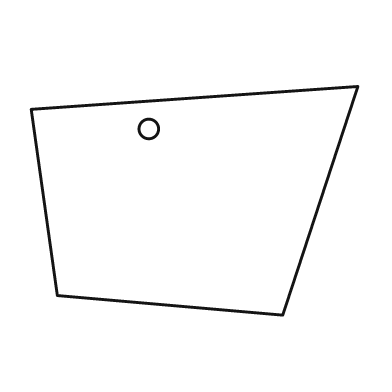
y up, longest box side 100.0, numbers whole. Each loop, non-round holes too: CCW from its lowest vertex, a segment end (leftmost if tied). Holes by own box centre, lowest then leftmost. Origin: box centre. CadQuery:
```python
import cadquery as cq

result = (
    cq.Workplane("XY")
    .moveTo(27.0, -35.0)
    .lineTo(50.0, 35.0)
    .lineTo(-50.0, 28.0)
    .lineTo(-42.0, -29.0)
    .close()
    .moveTo(-14.0, 22.0)
    .circle(3.0)
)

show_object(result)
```